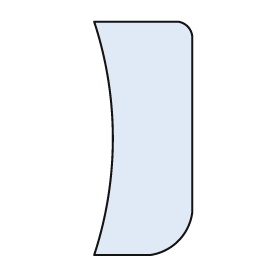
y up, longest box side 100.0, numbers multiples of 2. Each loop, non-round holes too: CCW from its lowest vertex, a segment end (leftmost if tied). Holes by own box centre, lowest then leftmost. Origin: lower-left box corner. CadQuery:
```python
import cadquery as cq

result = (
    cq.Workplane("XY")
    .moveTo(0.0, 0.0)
    .lineTo(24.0, 0.0)
    .threePointArc((36.0, 6.0), (42.0, 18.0))
    .lineTo(42.0, 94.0)
    .threePointArc((40.0, 98.0), (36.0, 100.0))
    .lineTo(0.0, 100.0)
    .threePointArc((8.0, 50.0), (0.0, 0.0))
    .close()
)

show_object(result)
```